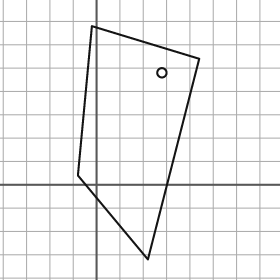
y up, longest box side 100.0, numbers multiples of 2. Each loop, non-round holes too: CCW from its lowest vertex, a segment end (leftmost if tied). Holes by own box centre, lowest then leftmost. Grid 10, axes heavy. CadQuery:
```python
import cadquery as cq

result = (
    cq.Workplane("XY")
    .moveTo(22.0, -32.0)
    .lineTo(44.0, 54.0)
    .lineTo(-2.0, 68.0)
    .lineTo(-8.0, 4.0)
    .close()
    .moveTo(28.0, 48.0)
    .circle(2.0)
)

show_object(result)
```